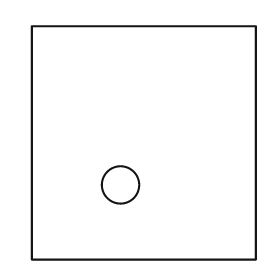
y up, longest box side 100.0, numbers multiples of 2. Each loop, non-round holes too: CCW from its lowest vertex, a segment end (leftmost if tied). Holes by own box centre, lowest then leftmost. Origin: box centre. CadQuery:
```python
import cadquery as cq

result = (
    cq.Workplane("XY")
    .moveTo(-48.0, -50.0)
    .lineTo(48.0, -50.0)
    .lineTo(48.0, 50.0)
    .lineTo(-48.0, 50.0)
    .close()
    .moveTo(-10.0, -18.0)
    .circle(8.0)
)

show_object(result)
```